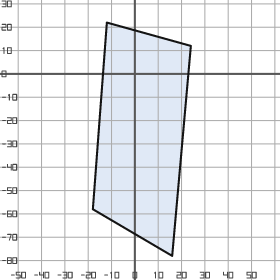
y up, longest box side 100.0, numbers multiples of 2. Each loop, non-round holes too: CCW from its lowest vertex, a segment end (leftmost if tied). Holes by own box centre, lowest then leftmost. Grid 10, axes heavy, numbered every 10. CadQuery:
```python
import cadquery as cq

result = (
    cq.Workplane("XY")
    .moveTo(16.0, -78.0)
    .lineTo(24.0, 12.0)
    .lineTo(-12.0, 22.0)
    .lineTo(-18.0, -58.0)
    .close()
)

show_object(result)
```